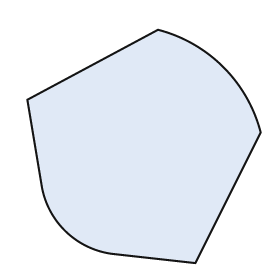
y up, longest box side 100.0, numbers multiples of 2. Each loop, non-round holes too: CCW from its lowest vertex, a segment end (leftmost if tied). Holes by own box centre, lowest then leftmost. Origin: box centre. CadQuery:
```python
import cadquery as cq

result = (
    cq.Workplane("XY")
    .moveTo(22.0, -50.0)
    .lineTo(50.0, 6.0)
    .threePointArc((34.0, 34.0), (6.0, 50.0))
    .lineTo(-50.0, 20.0)
    .lineTo(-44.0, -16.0)
    .threePointArc((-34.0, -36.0), (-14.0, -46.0))
    .close()
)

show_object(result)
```